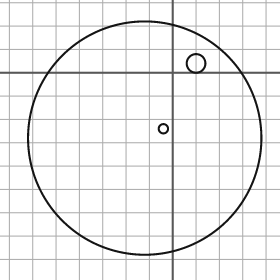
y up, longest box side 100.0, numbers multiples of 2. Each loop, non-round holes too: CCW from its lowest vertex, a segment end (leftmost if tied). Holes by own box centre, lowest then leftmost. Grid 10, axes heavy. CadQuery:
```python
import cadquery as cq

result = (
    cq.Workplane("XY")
    .moveTo(-12.0, -28.0)
    .circle(50.0)
    .moveTo(-4.0, -24.0)
    .circle(2.0)
    .moveTo(10.0, 4.0)
    .circle(4.0)
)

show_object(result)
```